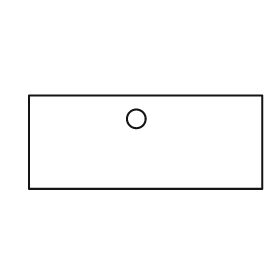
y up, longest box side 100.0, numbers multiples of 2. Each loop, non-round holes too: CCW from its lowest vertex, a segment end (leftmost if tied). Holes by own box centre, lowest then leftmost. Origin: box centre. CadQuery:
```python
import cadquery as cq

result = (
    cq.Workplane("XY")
    .moveTo(-50.0, -20.0)
    .lineTo(50.0, -20.0)
    .lineTo(50.0, 20.0)
    .lineTo(-50.0, 20.0)
    .close()
    .moveTo(-4.0, 10.0)
    .circle(4.0)
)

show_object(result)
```